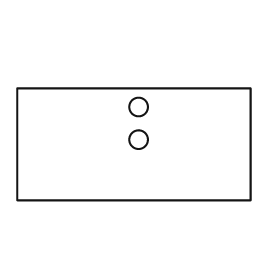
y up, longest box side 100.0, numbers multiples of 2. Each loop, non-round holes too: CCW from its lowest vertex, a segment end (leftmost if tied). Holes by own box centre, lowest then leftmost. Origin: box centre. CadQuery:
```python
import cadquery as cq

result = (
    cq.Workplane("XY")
    .moveTo(-50.0, -24.0)
    .lineTo(50.0, -24.0)
    .lineTo(50.0, 24.0)
    .lineTo(-50.0, 24.0)
    .close()
    .moveTo(2.0, 2.0)
    .circle(4.0)
    .moveTo(2.0, 16.0)
    .circle(4.0)
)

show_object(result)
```